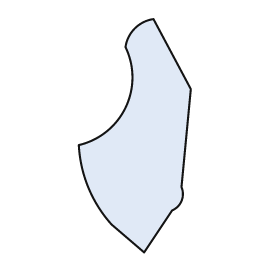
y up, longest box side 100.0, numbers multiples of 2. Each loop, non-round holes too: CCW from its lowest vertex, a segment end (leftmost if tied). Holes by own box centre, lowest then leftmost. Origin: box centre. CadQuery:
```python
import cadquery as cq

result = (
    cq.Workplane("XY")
    .moveTo(4.0, -50.0)
    .lineTo(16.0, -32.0)
    .threePointArc((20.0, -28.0), (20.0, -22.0))
    .lineTo(24.0, 20.0)
    .lineTo(8.0, 50.0)
    .threePointArc((0.0, 46.0), (-4.0, 38.0))
    .threePointArc((-4.0, 12.0), (-24.0, -4.0))
    .threePointArc((-20.0, -22.0), (-10.0, -38.0))
    .close()
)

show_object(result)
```